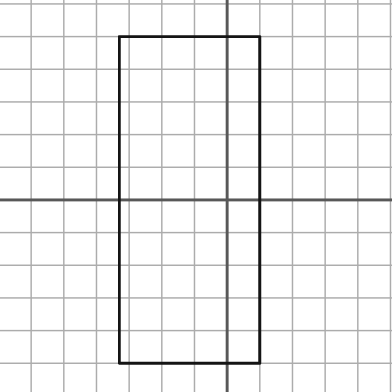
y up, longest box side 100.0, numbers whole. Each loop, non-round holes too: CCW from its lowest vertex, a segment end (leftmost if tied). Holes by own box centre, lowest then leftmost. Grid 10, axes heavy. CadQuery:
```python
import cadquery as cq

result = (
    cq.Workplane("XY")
    .moveTo(-33.0, -50.0)
    .lineTo(10.0, -50.0)
    .lineTo(10.0, 50.0)
    .lineTo(-33.0, 50.0)
    .close()
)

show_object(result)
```